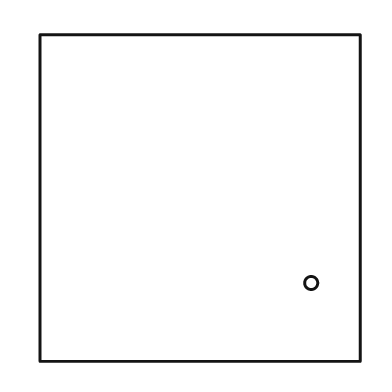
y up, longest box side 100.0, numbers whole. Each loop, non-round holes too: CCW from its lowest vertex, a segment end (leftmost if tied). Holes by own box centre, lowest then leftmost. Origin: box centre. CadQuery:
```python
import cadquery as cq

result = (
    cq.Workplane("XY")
    .moveTo(-49.0, -50.0)
    .lineTo(49.0, -50.0)
    .lineTo(49.0, 50.0)
    .lineTo(-49.0, 50.0)
    .close()
    .moveTo(34.0, -26.0)
    .circle(2.0)
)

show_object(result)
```